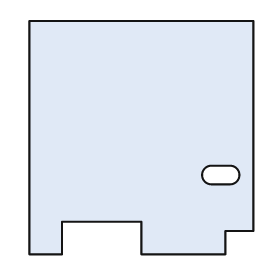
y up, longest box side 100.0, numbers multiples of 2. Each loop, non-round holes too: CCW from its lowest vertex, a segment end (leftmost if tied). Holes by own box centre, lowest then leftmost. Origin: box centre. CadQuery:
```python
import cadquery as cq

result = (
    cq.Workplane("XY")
    .moveTo(-48.0, -50.0)
    .lineTo(-34.0, -50.0)
    .lineTo(-34.0, -36.0)
    .lineTo(0.0, -36.0)
    .lineTo(0.0, -50.0)
    .lineTo(36.0, -50.0)
    .lineTo(36.0, -40.0)
    .lineTo(48.0, -40.0)
    .lineTo(48.0, 50.0)
    .lineTo(-48.0, 50.0)
    .close()
    .moveTo(30.0, -20.0)
    .lineTo(38.0, -20.0)
    .threePointArc((42.0, -16.0), (38.0, -12.0))
    .lineTo(30.0, -12.0)
    .threePointArc((26.0, -16.0), (30.0, -20.0))
    .close()
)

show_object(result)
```